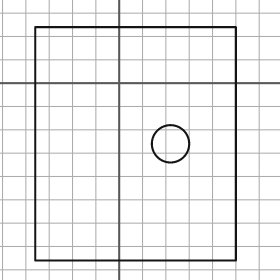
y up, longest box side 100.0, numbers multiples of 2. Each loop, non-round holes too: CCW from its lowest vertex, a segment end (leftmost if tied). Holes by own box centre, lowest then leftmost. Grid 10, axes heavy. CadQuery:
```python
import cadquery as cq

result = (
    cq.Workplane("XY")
    .moveTo(-36.0, -76.0)
    .lineTo(50.0, -76.0)
    .lineTo(50.0, 24.0)
    .lineTo(-36.0, 24.0)
    .close()
    .moveTo(22.0, -26.0)
    .circle(8.0)
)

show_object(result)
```